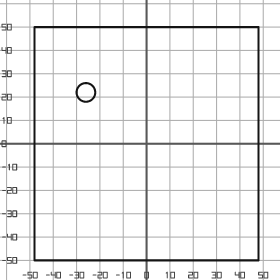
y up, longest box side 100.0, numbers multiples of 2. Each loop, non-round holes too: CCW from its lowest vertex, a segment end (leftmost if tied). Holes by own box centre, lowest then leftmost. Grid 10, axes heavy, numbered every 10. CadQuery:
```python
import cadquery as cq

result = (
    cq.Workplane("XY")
    .moveTo(-48.0, -50.0)
    .lineTo(48.0, -50.0)
    .lineTo(48.0, 50.0)
    .lineTo(-48.0, 50.0)
    .close()
    .moveTo(-26.0, 22.0)
    .circle(4.0)
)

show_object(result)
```